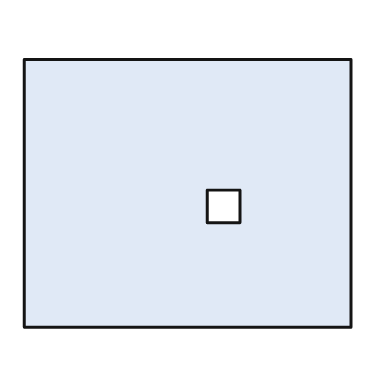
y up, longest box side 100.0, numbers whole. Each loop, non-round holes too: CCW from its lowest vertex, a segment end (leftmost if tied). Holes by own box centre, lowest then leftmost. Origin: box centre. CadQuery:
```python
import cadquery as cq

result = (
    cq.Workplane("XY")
    .moveTo(-50.0, -41.0)
    .lineTo(50.0, -41.0)
    .lineTo(50.0, 41.0)
    .lineTo(-50.0, 41.0)
    .close()
    .moveTo(6.0, -9.0)
    .lineTo(16.0, -9.0)
    .lineTo(16.0, 1.0)
    .lineTo(6.0, 1.0)
    .close()
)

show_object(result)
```